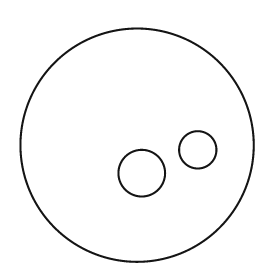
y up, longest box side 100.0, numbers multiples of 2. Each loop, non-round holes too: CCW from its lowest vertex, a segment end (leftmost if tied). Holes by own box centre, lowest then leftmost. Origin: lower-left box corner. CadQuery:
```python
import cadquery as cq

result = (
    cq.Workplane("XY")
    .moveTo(50.0, 50.0)
    .circle(50.0)
    .moveTo(52.0, 38.0)
    .circle(10.0)
    .moveTo(76.0, 48.0)
    .circle(8.0)
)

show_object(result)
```